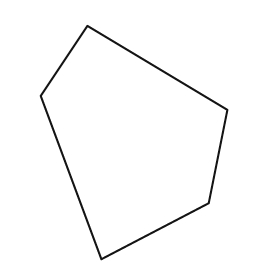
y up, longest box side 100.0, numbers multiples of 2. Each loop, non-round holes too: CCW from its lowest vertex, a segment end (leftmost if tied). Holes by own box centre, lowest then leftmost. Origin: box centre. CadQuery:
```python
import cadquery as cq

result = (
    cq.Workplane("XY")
    .moveTo(-14.0, -50.0)
    .lineTo(32.0, -26.0)
    .lineTo(40.0, 14.0)
    .lineTo(-20.0, 50.0)
    .lineTo(-40.0, 20.0)
    .close()
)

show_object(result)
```